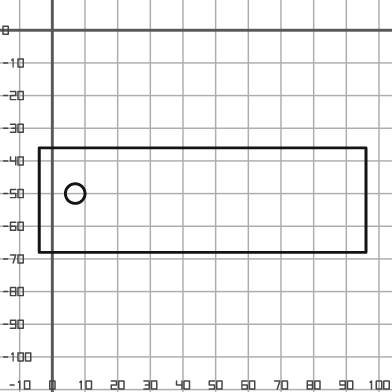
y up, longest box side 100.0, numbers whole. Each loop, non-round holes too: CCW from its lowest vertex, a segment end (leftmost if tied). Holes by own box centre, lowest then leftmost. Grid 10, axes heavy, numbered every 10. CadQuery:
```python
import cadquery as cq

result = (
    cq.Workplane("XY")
    .moveTo(-4.0, -68.0)
    .lineTo(96.0, -68.0)
    .lineTo(96.0, -36.0)
    .lineTo(-4.0, -36.0)
    .close()
    .moveTo(7.0, -50.0)
    .circle(3.0)
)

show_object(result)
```